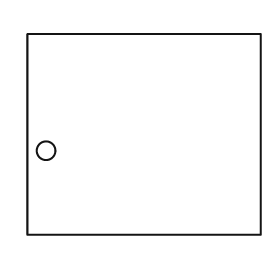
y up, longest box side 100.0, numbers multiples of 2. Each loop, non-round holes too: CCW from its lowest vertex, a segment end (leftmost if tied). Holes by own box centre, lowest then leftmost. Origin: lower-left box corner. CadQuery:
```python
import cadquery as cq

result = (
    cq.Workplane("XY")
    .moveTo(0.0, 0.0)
    .lineTo(100.0, 0.0)
    .lineTo(100.0, 86.0)
    .lineTo(0.0, 86.0)
    .close()
    .moveTo(8.0, 36.0)
    .circle(4.0)
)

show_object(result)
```